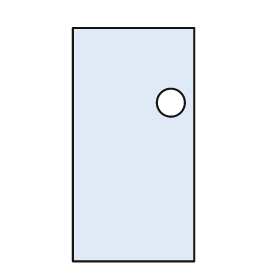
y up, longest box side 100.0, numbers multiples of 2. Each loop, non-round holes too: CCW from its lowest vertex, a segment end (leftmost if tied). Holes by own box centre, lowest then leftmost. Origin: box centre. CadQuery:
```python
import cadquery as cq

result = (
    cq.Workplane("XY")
    .moveTo(-26.0, -50.0)
    .lineTo(26.0, -50.0)
    .lineTo(26.0, 50.0)
    .lineTo(-26.0, 50.0)
    .close()
    .moveTo(16.0, 18.0)
    .circle(6.0)
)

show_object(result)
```